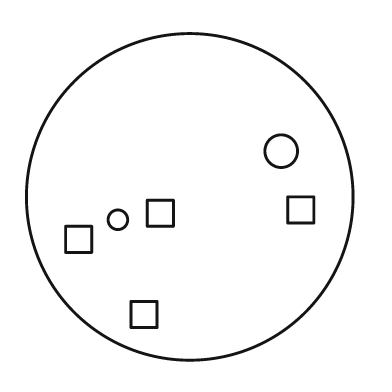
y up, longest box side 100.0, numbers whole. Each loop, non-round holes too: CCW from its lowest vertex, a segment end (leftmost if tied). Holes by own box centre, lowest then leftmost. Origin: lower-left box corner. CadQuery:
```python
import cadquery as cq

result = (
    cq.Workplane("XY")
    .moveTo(50.0, 50.0)
    .circle(50.0)
    .moveTo(32.0, 10.0)
    .lineTo(40.0, 10.0)
    .lineTo(40.0, 18.0)
    .lineTo(32.0, 18.0)
    .close()
    .moveTo(12.0, 33.0)
    .lineTo(20.0, 33.0)
    .lineTo(20.0, 41.0)
    .lineTo(12.0, 41.0)
    .close()
    .moveTo(28.0, 43.0)
    .circle(3.0)
    .moveTo(37.0, 41.0)
    .lineTo(45.0, 41.0)
    .lineTo(45.0, 49.0)
    .lineTo(37.0, 49.0)
    .close()
    .moveTo(80.0, 42.0)
    .lineTo(88.0, 42.0)
    .lineTo(88.0, 50.0)
    .lineTo(80.0, 50.0)
    .close()
    .moveTo(78.0, 64.0)
    .circle(5.0)
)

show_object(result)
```